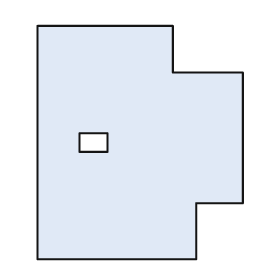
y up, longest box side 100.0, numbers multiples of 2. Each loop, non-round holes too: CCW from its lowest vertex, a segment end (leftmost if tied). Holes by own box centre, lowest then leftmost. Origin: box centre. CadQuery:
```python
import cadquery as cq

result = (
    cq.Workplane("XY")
    .moveTo(-44.0, -50.0)
    .lineTo(24.0, -50.0)
    .lineTo(24.0, -26.0)
    .lineTo(44.0, -26.0)
    .lineTo(44.0, 30.0)
    .lineTo(14.0, 30.0)
    .lineTo(14.0, 50.0)
    .lineTo(-44.0, 50.0)
    .close()
    .moveTo(-26.0, -4.0)
    .lineTo(-14.0, -4.0)
    .lineTo(-14.0, 4.0)
    .lineTo(-26.0, 4.0)
    .close()
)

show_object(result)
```